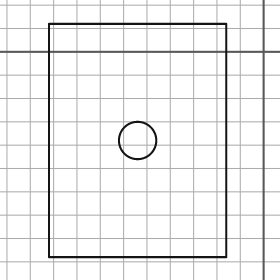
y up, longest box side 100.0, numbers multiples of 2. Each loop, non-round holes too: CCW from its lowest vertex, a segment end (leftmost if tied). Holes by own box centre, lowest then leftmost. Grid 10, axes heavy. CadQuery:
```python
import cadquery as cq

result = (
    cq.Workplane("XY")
    .moveTo(-92.0, -88.0)
    .lineTo(-16.0, -88.0)
    .lineTo(-16.0, 12.0)
    .lineTo(-92.0, 12.0)
    .close()
    .moveTo(-54.0, -38.0)
    .circle(8.0)
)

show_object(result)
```